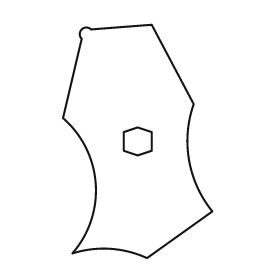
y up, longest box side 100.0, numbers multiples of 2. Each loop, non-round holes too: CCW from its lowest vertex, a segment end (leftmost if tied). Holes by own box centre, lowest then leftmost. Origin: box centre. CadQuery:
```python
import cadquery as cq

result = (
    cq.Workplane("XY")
    .moveTo(4.0, -50.0)
    .lineTo(32.0, -30.0)
    .threePointArc((22.0, -8.0), (24.0, 16.0))
    .lineTo(6.0, 50.0)
    .lineTo(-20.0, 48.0)
    .threePointArc((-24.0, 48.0), (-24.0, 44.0))
    .lineTo(-32.0, 10.0)
    .threePointArc((-18.0, -18.0), (-28.0, -48.0))
    .threePointArc((-12.0, -46.0), (4.0, -50.0))
    .close()
    .moveTo(0.0, -6.0)
    .lineTo(6.0, -4.0)
    .lineTo(6.0, 4.0)
    .lineTo(0.0, 6.0)
    .lineTo(-6.0, 4.0)
    .lineTo(-6.0, -4.0)
    .close()
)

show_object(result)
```